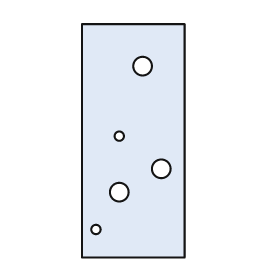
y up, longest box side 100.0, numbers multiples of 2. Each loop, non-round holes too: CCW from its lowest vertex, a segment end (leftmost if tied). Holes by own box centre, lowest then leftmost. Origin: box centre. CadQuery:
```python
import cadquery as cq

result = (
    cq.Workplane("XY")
    .moveTo(-22.0, -50.0)
    .lineTo(22.0, -50.0)
    .lineTo(22.0, 50.0)
    .lineTo(-22.0, 50.0)
    .close()
    .moveTo(-16.0, -38.0)
    .circle(2.0)
    .moveTo(-6.0, -22.0)
    .circle(4.0)
    .moveTo(12.0, -12.0)
    .circle(4.0)
    .moveTo(-6.0, 2.0)
    .circle(2.0)
    .moveTo(4.0, 32.0)
    .circle(4.0)
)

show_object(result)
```